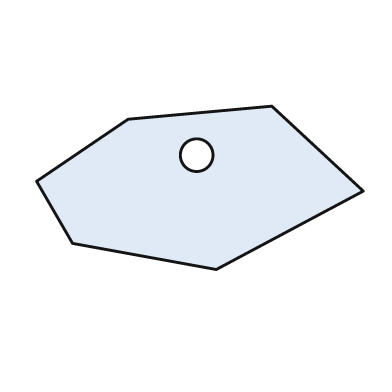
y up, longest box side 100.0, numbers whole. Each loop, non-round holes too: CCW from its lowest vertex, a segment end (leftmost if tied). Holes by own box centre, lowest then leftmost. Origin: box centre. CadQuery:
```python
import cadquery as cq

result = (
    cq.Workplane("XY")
    .moveTo(5.0, -25.0)
    .lineTo(50.0, -1.0)
    .lineTo(22.0, 25.0)
    .lineTo(-22.0, 21.0)
    .lineTo(-50.0, 2.0)
    .lineTo(-39.0, -17.0)
    .close()
    .moveTo(-1.0, 10.0)
    .circle(5.0)
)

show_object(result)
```